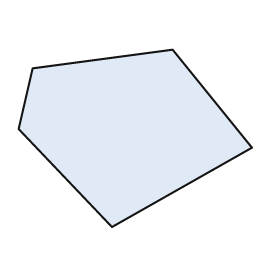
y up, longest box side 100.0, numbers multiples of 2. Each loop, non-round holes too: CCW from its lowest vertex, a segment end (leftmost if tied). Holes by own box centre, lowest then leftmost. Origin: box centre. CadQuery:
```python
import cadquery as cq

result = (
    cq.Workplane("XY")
    .moveTo(-10.0, -38.0)
    .lineTo(50.0, -4.0)
    .lineTo(16.0, 38.0)
    .lineTo(-44.0, 30.0)
    .lineTo(-50.0, 4.0)
    .close()
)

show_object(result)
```